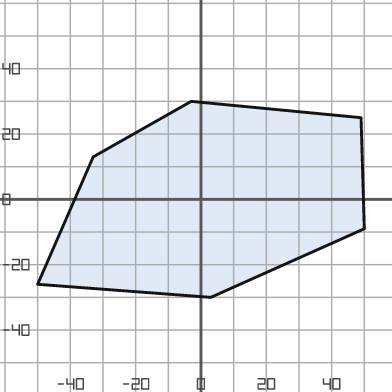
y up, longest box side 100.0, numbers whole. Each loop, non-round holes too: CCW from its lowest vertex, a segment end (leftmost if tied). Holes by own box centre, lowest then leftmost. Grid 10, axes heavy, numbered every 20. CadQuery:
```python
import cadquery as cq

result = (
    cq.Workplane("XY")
    .moveTo(3.0, -30.0)
    .lineTo(50.0, -9.0)
    .lineTo(49.0, 25.0)
    .lineTo(-3.0, 30.0)
    .lineTo(-33.0, 13.0)
    .lineTo(-50.0, -26.0)
    .close()
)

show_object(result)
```